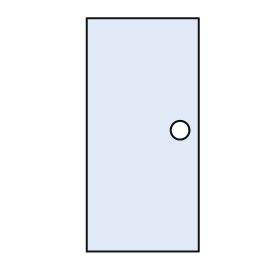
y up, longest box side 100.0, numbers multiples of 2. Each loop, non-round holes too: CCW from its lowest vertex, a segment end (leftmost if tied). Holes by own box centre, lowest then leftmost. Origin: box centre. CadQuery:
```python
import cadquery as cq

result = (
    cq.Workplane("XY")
    .moveTo(-24.0, -50.0)
    .lineTo(24.0, -50.0)
    .lineTo(24.0, 50.0)
    .lineTo(-24.0, 50.0)
    .close()
    .moveTo(16.0, 2.0)
    .circle(4.0)
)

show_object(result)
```